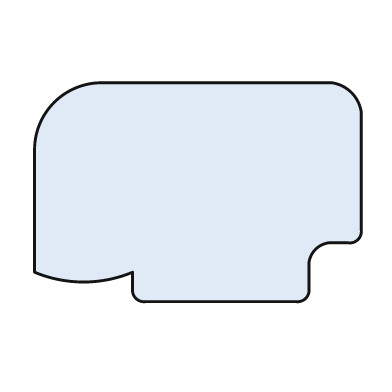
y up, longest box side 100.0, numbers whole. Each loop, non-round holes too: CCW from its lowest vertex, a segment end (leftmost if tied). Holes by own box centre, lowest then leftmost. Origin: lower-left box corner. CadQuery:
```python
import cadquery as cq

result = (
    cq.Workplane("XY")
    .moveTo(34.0, 0.0)
    .lineTo(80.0, 0.0)
    .threePointArc((83.0, 1.0), (84.0, 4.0))
    .lineTo(84.0, 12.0)
    .threePointArc((86.0, 16.0), (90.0, 18.0))
    .lineTo(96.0, 18.0)
    .threePointArc((99.0, 19.0), (100.0, 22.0))
    .lineTo(100.0, 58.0)
    .threePointArc((97.0, 64.0), (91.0, 67.0))
    .lineTo(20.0, 67.0)
    .threePointArc((6.0, 61.0), (0.0, 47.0))
    .lineTo(0.0, 9.0)
    .threePointArc((15.0, 6.0), (30.0, 9.0))
    .lineTo(30.0, 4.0)
    .threePointArc((31.0, 1.0), (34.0, 0.0))
    .close()
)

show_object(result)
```